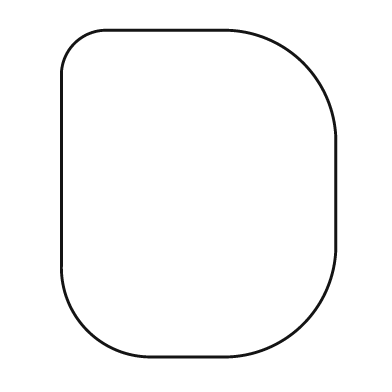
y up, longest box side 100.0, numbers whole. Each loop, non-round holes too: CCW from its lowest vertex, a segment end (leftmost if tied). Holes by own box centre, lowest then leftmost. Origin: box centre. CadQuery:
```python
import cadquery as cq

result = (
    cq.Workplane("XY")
    .moveTo(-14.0, -50.0)
    .lineTo(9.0, -50.0)
    .threePointArc((32.0, -40.0), (42.0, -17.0))
    .lineTo(42.0, 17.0)
    .threePointArc((32.0, 40.0), (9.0, 50.0))
    .lineTo(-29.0, 50.0)
    .threePointArc((-38.0, 46.0), (-42.0, 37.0))
    .lineTo(-42.0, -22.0)
    .threePointArc((-34.0, -42.0), (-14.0, -50.0))
    .close()
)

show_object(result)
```